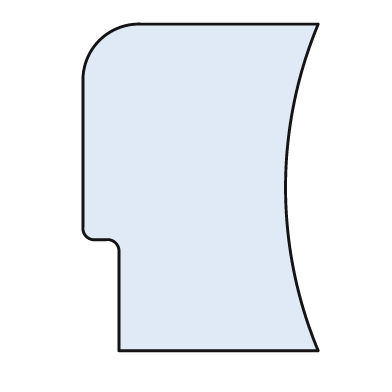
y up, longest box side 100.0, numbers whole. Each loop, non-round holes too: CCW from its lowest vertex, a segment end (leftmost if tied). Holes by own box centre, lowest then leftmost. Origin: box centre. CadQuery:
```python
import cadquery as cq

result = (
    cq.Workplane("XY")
    .moveTo(-25.0, -50.0)
    .lineTo(36.0, -50.0)
    .threePointArc((26.0, 0.0), (36.0, 50.0))
    .lineTo(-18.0, 50.0)
    .threePointArc((-31.0, 45.0), (-36.0, 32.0))
    .lineTo(-36.0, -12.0)
    .threePointArc((-35.0, -15.0), (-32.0, -16.0))
    .lineTo(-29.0, -16.0)
    .threePointArc((-26.0, -17.0), (-25.0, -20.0))
    .close()
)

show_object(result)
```